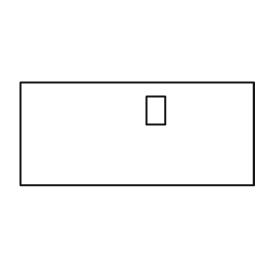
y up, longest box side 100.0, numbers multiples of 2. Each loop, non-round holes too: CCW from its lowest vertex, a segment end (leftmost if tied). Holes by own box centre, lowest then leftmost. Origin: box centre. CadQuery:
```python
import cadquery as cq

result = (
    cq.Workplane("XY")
    .moveTo(-50.0, -22.0)
    .lineTo(50.0, -22.0)
    .lineTo(50.0, 22.0)
    .lineTo(-50.0, 22.0)
    .close()
    .moveTo(4.0, 4.0)
    .lineTo(12.0, 4.0)
    .lineTo(12.0, 16.0)
    .lineTo(4.0, 16.0)
    .close()
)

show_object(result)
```